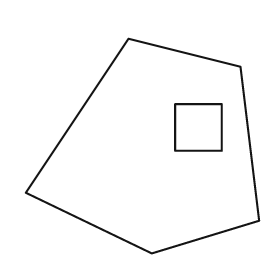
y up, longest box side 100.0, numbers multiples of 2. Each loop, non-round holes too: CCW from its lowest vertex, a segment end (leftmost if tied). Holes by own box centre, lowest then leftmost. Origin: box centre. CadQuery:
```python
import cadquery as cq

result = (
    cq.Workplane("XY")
    .moveTo(4.0, -46.0)
    .lineTo(50.0, -32.0)
    .lineTo(42.0, 34.0)
    .lineTo(-6.0, 46.0)
    .lineTo(-50.0, -20.0)
    .close()
    .moveTo(14.0, -2.0)
    .lineTo(34.0, -2.0)
    .lineTo(34.0, 18.0)
    .lineTo(14.0, 18.0)
    .close()
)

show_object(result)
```